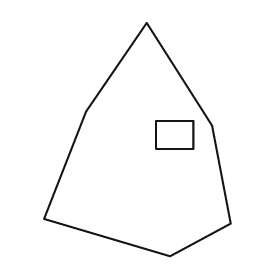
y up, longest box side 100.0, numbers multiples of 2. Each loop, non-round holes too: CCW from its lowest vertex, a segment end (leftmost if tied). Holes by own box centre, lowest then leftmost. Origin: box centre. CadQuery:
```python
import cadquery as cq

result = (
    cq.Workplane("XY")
    .moveTo(14.0, -50.0)
    .lineTo(40.0, -36.0)
    .lineTo(32.0, 6.0)
    .lineTo(4.0, 50.0)
    .lineTo(-22.0, 12.0)
    .lineTo(-40.0, -34.0)
    .close()
    .moveTo(8.0, -4.0)
    .lineTo(24.0, -4.0)
    .lineTo(24.0, 8.0)
    .lineTo(8.0, 8.0)
    .close()
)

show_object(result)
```